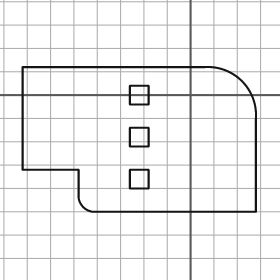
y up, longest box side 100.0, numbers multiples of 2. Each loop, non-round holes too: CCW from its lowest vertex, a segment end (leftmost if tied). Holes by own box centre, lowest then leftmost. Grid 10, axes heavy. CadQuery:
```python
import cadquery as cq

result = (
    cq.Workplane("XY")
    .moveTo(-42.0, -50.0)
    .lineTo(28.0, -50.0)
    .lineTo(28.0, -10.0)
    .threePointArc((22.0, 6.0), (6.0, 12.0))
    .lineTo(-72.0, 12.0)
    .lineTo(-72.0, -32.0)
    .lineTo(-48.0, -32.0)
    .lineTo(-48.0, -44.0)
    .threePointArc((-46.0, -48.0), (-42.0, -50.0))
    .close()
    .moveTo(-26.0, -40.0)
    .lineTo(-18.0, -40.0)
    .lineTo(-18.0, -32.0)
    .lineTo(-26.0, -32.0)
    .close()
    .moveTo(-26.0, -22.0)
    .lineTo(-18.0, -22.0)
    .lineTo(-18.0, -14.0)
    .lineTo(-26.0, -14.0)
    .close()
    .moveTo(-26.0, -4.0)
    .lineTo(-18.0, -4.0)
    .lineTo(-18.0, 4.0)
    .lineTo(-26.0, 4.0)
    .close()
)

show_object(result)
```